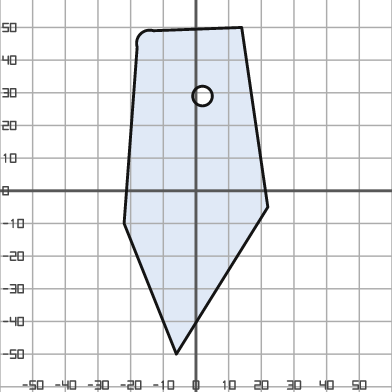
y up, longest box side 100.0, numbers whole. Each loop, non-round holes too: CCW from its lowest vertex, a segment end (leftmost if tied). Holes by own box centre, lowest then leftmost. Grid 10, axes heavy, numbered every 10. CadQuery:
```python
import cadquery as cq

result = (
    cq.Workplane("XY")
    .moveTo(-6.0, -50.0)
    .lineTo(22.0, -5.0)
    .lineTo(14.0, 50.0)
    .lineTo(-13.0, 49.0)
    .threePointArc((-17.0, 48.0), (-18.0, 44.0))
    .lineTo(-22.0, -10.0)
    .close()
    .moveTo(2.0, 29.0)
    .circle(3.0)
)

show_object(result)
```